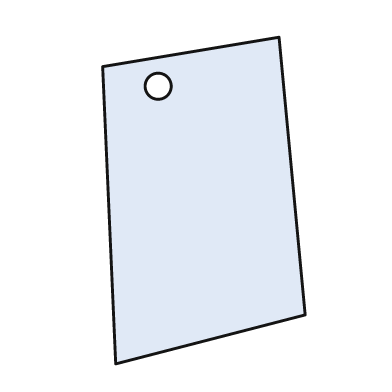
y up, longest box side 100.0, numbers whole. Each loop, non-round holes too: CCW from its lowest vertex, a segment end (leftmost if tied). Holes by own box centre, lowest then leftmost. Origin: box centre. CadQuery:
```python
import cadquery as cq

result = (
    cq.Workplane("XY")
    .moveTo(-27.0, -50.0)
    .lineTo(31.0, -35.0)
    .lineTo(23.0, 50.0)
    .lineTo(-31.0, 41.0)
    .close()
    .moveTo(-14.0, 35.0)
    .circle(4.0)
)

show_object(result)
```